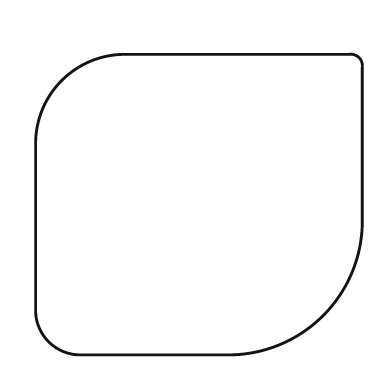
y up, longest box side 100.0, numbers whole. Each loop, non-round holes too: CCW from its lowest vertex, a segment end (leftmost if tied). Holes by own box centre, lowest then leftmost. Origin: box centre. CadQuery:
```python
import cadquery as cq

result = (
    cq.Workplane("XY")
    .moveTo(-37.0, -46.0)
    .lineTo(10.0, -46.0)
    .threePointArc((38.0, -34.0), (50.0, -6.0))
    .lineTo(50.0, 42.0)
    .threePointArc((49.0, 45.0), (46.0, 46.0))
    .lineTo(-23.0, 46.0)
    .threePointArc((-42.0, 38.0), (-50.0, 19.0))
    .lineTo(-50.0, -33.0)
    .threePointArc((-46.0, -42.0), (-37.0, -46.0))
    .close()
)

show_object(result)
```